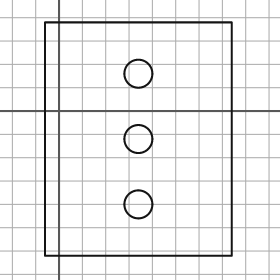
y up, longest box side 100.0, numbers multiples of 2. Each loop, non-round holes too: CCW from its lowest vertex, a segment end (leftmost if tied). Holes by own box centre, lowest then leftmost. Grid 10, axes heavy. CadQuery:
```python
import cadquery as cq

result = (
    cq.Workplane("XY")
    .moveTo(-6.0, -62.0)
    .lineTo(74.0, -62.0)
    .lineTo(74.0, 38.0)
    .lineTo(-6.0, 38.0)
    .close()
    .moveTo(34.0, -40.0)
    .circle(6.0)
    .moveTo(34.0, -12.0)
    .circle(6.0)
    .moveTo(34.0, 16.0)
    .circle(6.0)
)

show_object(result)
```